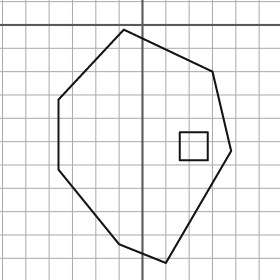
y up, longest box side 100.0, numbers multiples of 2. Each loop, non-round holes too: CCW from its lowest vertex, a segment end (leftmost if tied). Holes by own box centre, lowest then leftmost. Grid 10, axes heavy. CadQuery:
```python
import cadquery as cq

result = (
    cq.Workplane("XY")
    .moveTo(10.0, -102.0)
    .lineTo(38.0, -54.0)
    .lineTo(30.0, -20.0)
    .lineTo(-8.0, -2.0)
    .lineTo(-36.0, -32.0)
    .lineTo(-36.0, -62.0)
    .lineTo(-10.0, -94.0)
    .close()
    .moveTo(16.0, -58.0)
    .lineTo(28.0, -58.0)
    .lineTo(28.0, -46.0)
    .lineTo(16.0, -46.0)
    .close()
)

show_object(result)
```